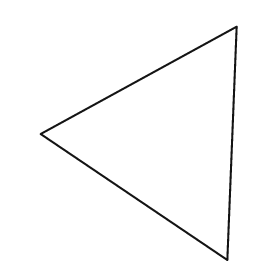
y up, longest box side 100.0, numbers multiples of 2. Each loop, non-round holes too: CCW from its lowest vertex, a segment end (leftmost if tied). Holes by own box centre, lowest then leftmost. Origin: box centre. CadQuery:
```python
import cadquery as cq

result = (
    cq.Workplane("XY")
    .moveTo(38.0, -50.0)
    .lineTo(42.0, 50.0)
    .lineTo(-42.0, 4.0)
    .close()
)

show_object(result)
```